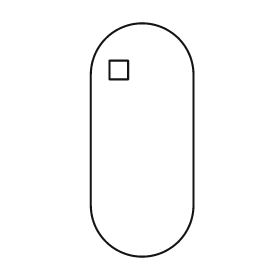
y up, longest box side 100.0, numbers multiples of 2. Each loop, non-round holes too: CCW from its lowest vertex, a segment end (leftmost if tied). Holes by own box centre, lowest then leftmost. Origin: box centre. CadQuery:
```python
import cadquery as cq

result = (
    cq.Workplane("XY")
    .moveTo(-22.0, -28.0)
    .threePointArc((0.0, -50.0), (22.0, -28.0))
    .lineTo(22.0, 28.0)
    .threePointArc((0.0, 50.0), (-22.0, 28.0))
    .close()
    .moveTo(-14.0, 26.0)
    .lineTo(-6.0, 26.0)
    .lineTo(-6.0, 34.0)
    .lineTo(-14.0, 34.0)
    .close()
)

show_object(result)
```